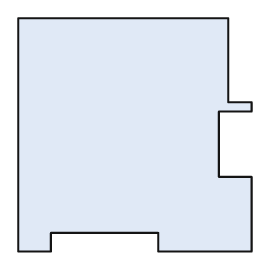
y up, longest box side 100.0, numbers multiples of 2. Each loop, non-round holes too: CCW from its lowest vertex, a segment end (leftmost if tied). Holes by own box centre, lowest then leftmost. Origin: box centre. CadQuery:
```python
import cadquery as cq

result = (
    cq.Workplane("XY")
    .moveTo(-50.0, -50.0)
    .lineTo(-36.0, -50.0)
    .lineTo(-36.0, -42.0)
    .lineTo(10.0, -42.0)
    .lineTo(10.0, -50.0)
    .lineTo(50.0, -50.0)
    .lineTo(50.0, -18.0)
    .lineTo(36.0, -18.0)
    .lineTo(36.0, 10.0)
    .lineTo(50.0, 10.0)
    .lineTo(50.0, 14.0)
    .lineTo(40.0, 14.0)
    .lineTo(40.0, 50.0)
    .lineTo(-50.0, 50.0)
    .close()
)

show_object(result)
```